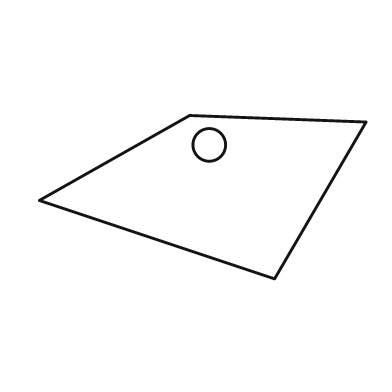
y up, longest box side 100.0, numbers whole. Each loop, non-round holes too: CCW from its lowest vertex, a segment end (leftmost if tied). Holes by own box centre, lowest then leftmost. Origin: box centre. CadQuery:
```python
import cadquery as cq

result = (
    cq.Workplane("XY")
    .moveTo(22.0, -25.0)
    .lineTo(50.0, 23.0)
    .lineTo(-4.0, 25.0)
    .lineTo(-50.0, -1.0)
    .close()
    .moveTo(2.0, 16.0)
    .circle(5.0)
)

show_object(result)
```